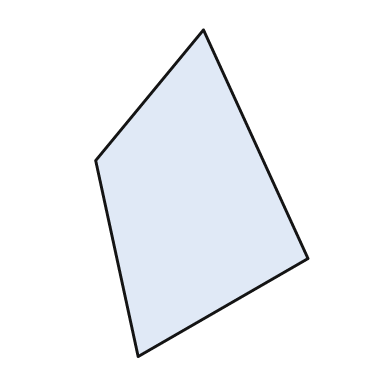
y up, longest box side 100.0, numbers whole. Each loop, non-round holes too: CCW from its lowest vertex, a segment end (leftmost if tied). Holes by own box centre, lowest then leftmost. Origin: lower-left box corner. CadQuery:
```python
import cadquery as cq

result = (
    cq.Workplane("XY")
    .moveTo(13.0, 0.0)
    .lineTo(65.0, 30.0)
    .lineTo(33.0, 100.0)
    .lineTo(0.0, 60.0)
    .close()
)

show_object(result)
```